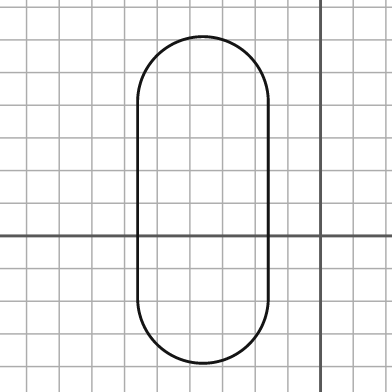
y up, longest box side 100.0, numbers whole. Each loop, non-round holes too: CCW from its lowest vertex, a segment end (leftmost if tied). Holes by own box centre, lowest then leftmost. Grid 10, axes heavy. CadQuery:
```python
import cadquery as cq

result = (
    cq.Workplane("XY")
    .moveTo(-56.0, -19.0)
    .threePointArc((-36.0, -39.0), (-16.0, -19.0))
    .lineTo(-16.0, 41.0)
    .threePointArc((-36.0, 61.0), (-56.0, 41.0))
    .close()
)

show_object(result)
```